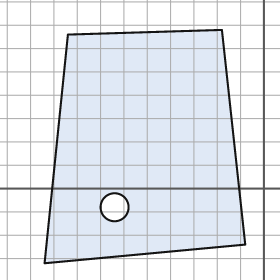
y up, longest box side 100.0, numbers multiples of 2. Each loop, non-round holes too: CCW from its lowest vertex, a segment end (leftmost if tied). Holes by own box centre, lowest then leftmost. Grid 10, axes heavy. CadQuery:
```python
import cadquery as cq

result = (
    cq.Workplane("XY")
    .moveTo(-94.0, -32.0)
    .lineTo(-8.0, -24.0)
    .lineTo(-18.0, 68.0)
    .lineTo(-84.0, 66.0)
    .close()
    .moveTo(-64.0, -8.0)
    .circle(6.0)
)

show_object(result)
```